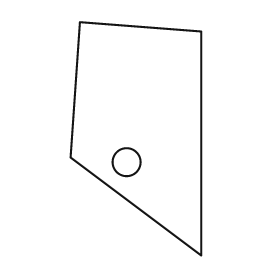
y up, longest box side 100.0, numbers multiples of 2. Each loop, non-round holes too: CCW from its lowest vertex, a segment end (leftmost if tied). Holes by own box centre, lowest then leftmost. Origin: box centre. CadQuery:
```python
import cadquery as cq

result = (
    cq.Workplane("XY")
    .moveTo(28.0, -50.0)
    .lineTo(28.0, 46.0)
    .lineTo(-24.0, 50.0)
    .lineTo(-28.0, -8.0)
    .close()
    .moveTo(-4.0, -10.0)
    .circle(6.0)
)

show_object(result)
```